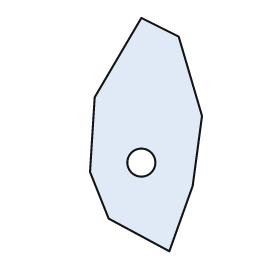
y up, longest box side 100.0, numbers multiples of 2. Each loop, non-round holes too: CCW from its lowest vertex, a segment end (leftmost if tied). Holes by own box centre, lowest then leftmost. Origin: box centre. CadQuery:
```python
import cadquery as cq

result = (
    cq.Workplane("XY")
    .moveTo(10.0, -50.0)
    .lineTo(20.0, -22.0)
    .lineTo(24.0, 8.0)
    .lineTo(14.0, 42.0)
    .lineTo(-2.0, 50.0)
    .lineTo(-22.0, 16.0)
    .lineTo(-24.0, -16.0)
    .lineTo(-16.0, -36.0)
    .close()
    .moveTo(-2.0, -12.0)
    .circle(6.0)
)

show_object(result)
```